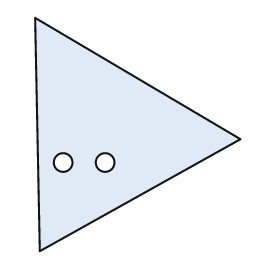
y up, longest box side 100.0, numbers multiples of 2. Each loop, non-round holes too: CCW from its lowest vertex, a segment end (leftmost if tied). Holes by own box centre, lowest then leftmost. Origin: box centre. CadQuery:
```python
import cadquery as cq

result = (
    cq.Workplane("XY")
    .moveTo(-42.0, -50.0)
    .lineTo(44.0, -2.0)
    .lineTo(-44.0, 50.0)
    .close()
    .moveTo(-32.0, -12.0)
    .circle(4.0)
    .moveTo(-14.0, -12.0)
    .circle(4.0)
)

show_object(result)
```